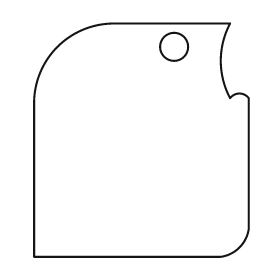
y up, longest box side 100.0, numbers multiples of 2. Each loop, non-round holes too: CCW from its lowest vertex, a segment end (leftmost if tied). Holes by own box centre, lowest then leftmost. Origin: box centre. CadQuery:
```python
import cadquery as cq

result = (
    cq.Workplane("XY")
    .moveTo(-46.0, -50.0)
    .lineTo(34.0, -50.0)
    .threePointArc((42.0, -46.0), (46.0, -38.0))
    .lineTo(46.0, 18.0)
    .threePointArc((42.0, 20.0), (38.0, 18.0))
    .threePointArc((34.0, 34.0), (38.0, 50.0))
    .lineTo(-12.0, 50.0)
    .threePointArc((-36.0, 40.0), (-46.0, 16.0))
    .close()
    .moveTo(14.0, 40.0)
    .circle(6.0)
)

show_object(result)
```